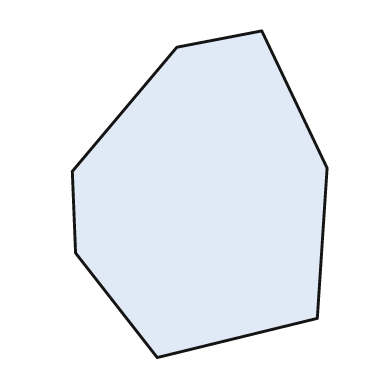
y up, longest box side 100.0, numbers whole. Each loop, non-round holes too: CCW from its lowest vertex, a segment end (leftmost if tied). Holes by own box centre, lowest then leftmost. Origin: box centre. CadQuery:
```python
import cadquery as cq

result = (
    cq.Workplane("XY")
    .moveTo(-13.0, -50.0)
    .lineTo(36.0, -38.0)
    .lineTo(39.0, 8.0)
    .lineTo(19.0, 50.0)
    .lineTo(-7.0, 45.0)
    .lineTo(-39.0, 7.0)
    .lineTo(-38.0, -18.0)
    .close()
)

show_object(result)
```